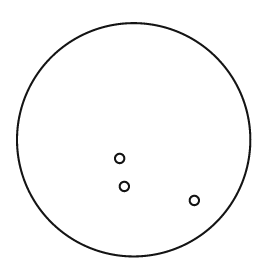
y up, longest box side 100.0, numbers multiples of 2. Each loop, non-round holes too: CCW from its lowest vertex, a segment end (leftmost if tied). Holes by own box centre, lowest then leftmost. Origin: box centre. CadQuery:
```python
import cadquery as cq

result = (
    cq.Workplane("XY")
    .moveTo(0.0, 0.0)
    .circle(50.0)
    .moveTo(26.0, -26.0)
    .circle(2.0)
    .moveTo(-4.0, -20.0)
    .circle(2.0)
    .moveTo(-6.0, -8.0)
    .circle(2.0)
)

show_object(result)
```